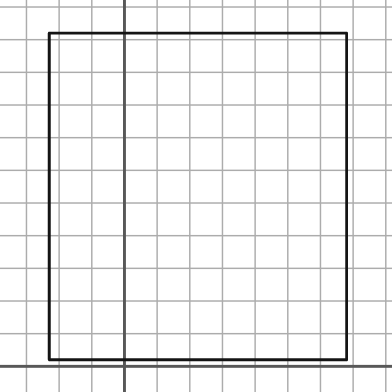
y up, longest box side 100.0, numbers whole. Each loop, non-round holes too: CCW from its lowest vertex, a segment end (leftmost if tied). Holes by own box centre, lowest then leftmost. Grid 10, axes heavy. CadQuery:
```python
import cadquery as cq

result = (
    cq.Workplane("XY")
    .moveTo(-23.0, 2.0)
    .lineTo(68.0, 2.0)
    .lineTo(68.0, 102.0)
    .lineTo(-23.0, 102.0)
    .close()
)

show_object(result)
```